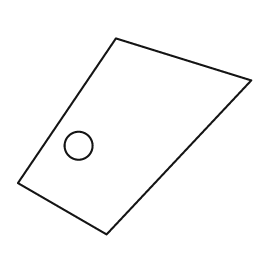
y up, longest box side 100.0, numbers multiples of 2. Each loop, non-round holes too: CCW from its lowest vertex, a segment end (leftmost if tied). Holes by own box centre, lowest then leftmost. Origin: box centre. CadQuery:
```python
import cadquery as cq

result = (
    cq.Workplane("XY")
    .moveTo(-12.0, -42.0)
    .lineTo(50.0, 24.0)
    .lineTo(-8.0, 42.0)
    .lineTo(-50.0, -20.0)
    .close()
    .moveTo(-24.0, -4.0)
    .circle(6.0)
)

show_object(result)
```